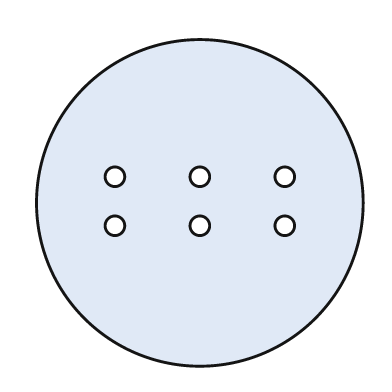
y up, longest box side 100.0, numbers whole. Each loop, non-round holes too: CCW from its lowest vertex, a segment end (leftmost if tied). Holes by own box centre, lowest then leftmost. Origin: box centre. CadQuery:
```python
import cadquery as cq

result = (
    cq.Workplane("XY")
    .moveTo(0.0, 0.0)
    .circle(50.0)
    .moveTo(-26.0, -7.0)
    .circle(3.0)
    .moveTo(0.0, -7.0)
    .circle(3.0)
    .moveTo(26.0, -7.0)
    .circle(3.0)
    .moveTo(-26.0, 8.0)
    .circle(3.0)
    .moveTo(0.0, 8.0)
    .circle(3.0)
    .moveTo(26.0, 8.0)
    .circle(3.0)
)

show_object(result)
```